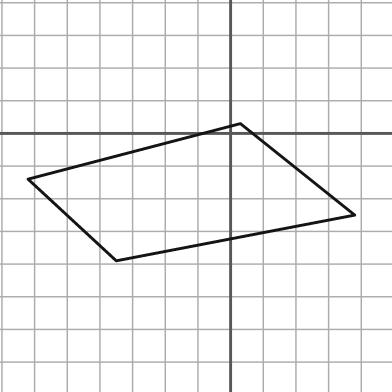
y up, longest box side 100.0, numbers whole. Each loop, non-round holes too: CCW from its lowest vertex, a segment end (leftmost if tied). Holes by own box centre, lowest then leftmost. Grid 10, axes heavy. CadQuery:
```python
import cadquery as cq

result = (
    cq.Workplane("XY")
    .moveTo(-35.0, -39.0)
    .lineTo(38.0, -25.0)
    .lineTo(3.0, 3.0)
    .lineTo(-62.0, -14.0)
    .close()
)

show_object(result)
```